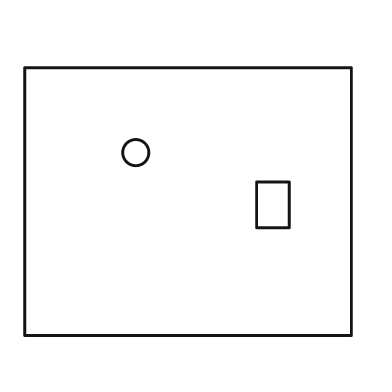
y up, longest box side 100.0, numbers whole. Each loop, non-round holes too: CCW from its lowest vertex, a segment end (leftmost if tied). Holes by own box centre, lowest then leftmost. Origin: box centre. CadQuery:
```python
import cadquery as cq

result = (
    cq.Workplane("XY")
    .moveTo(-50.0, -41.0)
    .lineTo(50.0, -41.0)
    .lineTo(50.0, 41.0)
    .lineTo(-50.0, 41.0)
    .close()
    .moveTo(21.0, -8.0)
    .lineTo(31.0, -8.0)
    .lineTo(31.0, 6.0)
    .lineTo(21.0, 6.0)
    .close()
    .moveTo(-16.0, 15.0)
    .circle(4.0)
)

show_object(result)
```